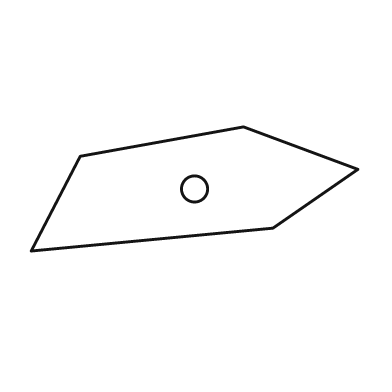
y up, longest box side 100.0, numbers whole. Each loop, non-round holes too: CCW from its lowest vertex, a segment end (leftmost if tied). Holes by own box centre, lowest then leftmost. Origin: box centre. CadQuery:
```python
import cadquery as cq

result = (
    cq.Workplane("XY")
    .moveTo(-50.0, -19.0)
    .lineTo(24.0, -12.0)
    .lineTo(50.0, 6.0)
    .lineTo(15.0, 19.0)
    .lineTo(-35.0, 10.0)
    .close()
    .moveTo(0.0, 0.0)
    .circle(4.0)
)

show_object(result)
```